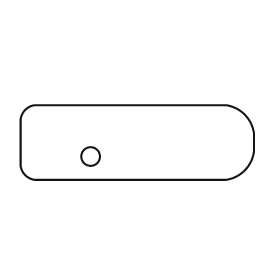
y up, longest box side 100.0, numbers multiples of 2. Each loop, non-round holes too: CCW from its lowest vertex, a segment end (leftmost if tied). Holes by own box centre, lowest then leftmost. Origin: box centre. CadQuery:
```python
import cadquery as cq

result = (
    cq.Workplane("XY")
    .moveTo(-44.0, -16.0)
    .lineTo(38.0, -16.0)
    .threePointArc((46.0, -12.0), (50.0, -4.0))
    .lineTo(50.0, 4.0)
    .threePointArc((46.0, 12.0), (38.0, 16.0))
    .lineTo(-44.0, 16.0)
    .threePointArc((-48.0, 14.0), (-50.0, 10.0))
    .lineTo(-50.0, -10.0)
    .threePointArc((-48.0, -14.0), (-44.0, -16.0))
    .close()
    .moveTo(-20.0, -6.0)
    .circle(4.0)
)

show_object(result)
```